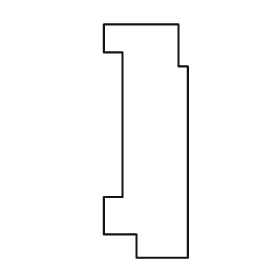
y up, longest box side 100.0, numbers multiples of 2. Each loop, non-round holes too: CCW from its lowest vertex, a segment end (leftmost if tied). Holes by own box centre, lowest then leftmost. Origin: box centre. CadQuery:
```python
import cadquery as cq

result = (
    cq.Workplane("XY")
    .moveTo(-4.0, -50.0)
    .lineTo(18.0, -50.0)
    .lineTo(18.0, 32.0)
    .lineTo(14.0, 32.0)
    .lineTo(14.0, 50.0)
    .lineTo(-18.0, 50.0)
    .lineTo(-18.0, 38.0)
    .lineTo(-10.0, 38.0)
    .lineTo(-10.0, -24.0)
    .lineTo(-18.0, -24.0)
    .lineTo(-18.0, -40.0)
    .lineTo(-4.0, -40.0)
    .close()
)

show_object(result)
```